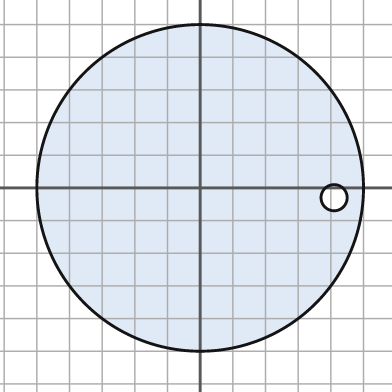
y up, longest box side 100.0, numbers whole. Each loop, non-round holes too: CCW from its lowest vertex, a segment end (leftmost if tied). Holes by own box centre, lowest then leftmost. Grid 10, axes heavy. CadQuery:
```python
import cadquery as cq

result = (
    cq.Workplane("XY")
    .moveTo(0.0, 0.0)
    .circle(50.0)
    .moveTo(41.0, -3.0)
    .circle(4.0)
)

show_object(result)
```